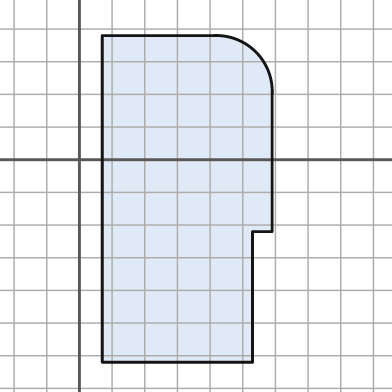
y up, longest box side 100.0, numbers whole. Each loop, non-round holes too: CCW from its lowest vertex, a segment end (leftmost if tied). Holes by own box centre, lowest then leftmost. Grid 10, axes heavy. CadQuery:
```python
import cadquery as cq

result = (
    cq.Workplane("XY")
    .moveTo(7.0, -62.0)
    .lineTo(53.0, -62.0)
    .lineTo(53.0, -22.0)
    .lineTo(59.0, -22.0)
    .lineTo(59.0, 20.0)
    .threePointArc((54.0, 33.0), (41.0, 38.0))
    .lineTo(7.0, 38.0)
    .close()
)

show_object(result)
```